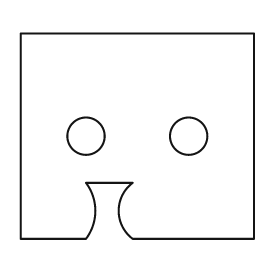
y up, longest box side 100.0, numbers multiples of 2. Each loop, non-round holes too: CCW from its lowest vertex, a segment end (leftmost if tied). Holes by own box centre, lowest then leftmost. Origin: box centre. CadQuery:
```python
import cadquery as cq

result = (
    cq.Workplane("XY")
    .moveTo(-50.0, -44.0)
    .lineTo(-22.0, -44.0)
    .threePointArc((-18.0, -32.0), (-22.0, -20.0))
    .lineTo(-2.0, -20.0)
    .threePointArc((-8.0, -32.0), (-2.0, -44.0))
    .lineTo(50.0, -44.0)
    .lineTo(50.0, 44.0)
    .lineTo(-50.0, 44.0)
    .close()
    .moveTo(-22.0, 0.0)
    .circle(8.0)
    .moveTo(22.0, 0.0)
    .circle(8.0)
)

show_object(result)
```